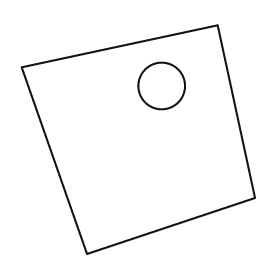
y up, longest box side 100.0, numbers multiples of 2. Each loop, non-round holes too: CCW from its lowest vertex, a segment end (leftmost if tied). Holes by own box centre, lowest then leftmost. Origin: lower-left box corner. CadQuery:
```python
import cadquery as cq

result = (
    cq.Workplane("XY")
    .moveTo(28.0, 0.0)
    .lineTo(100.0, 24.0)
    .lineTo(84.0, 98.0)
    .lineTo(0.0, 80.0)
    .close()
    .moveTo(60.0, 72.0)
    .circle(10.0)
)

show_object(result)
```